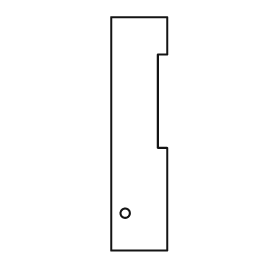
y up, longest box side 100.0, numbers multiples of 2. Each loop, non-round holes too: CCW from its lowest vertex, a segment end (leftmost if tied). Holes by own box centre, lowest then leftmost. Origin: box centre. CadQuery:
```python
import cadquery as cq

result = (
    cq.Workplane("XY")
    .moveTo(-12.0, -50.0)
    .lineTo(12.0, -50.0)
    .lineTo(12.0, -6.0)
    .lineTo(8.0, -6.0)
    .lineTo(8.0, 34.0)
    .lineTo(12.0, 34.0)
    .lineTo(12.0, 50.0)
    .lineTo(-12.0, 50.0)
    .close()
    .moveTo(-6.0, -34.0)
    .circle(2.0)
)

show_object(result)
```